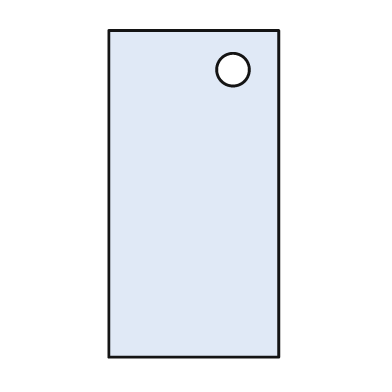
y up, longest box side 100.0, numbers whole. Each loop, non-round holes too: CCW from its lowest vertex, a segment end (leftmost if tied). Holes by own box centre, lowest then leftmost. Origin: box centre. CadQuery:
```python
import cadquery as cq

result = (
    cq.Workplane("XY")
    .moveTo(-26.0, -50.0)
    .lineTo(26.0, -50.0)
    .lineTo(26.0, 50.0)
    .lineTo(-26.0, 50.0)
    .close()
    .moveTo(12.0, 38.0)
    .circle(5.0)
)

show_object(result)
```